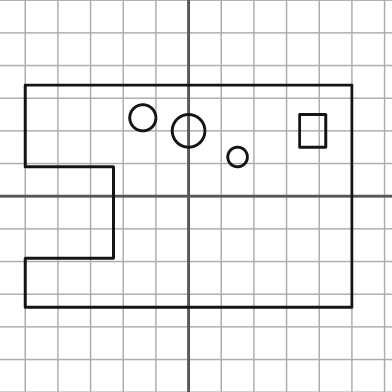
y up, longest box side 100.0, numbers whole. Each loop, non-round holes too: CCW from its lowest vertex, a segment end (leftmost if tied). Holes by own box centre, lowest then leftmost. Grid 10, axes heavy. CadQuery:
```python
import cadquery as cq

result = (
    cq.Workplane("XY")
    .moveTo(-50.0, -34.0)
    .lineTo(50.0, -34.0)
    .lineTo(50.0, 34.0)
    .lineTo(-50.0, 34.0)
    .lineTo(-50.0, 9.0)
    .lineTo(-23.0, 9.0)
    .lineTo(-23.0, -19.0)
    .lineTo(-50.0, -19.0)
    .close()
    .moveTo(15.0, 12.0)
    .circle(3.0)
    .moveTo(0.0, 20.0)
    .circle(5.0)
    .moveTo(34.0, 15.0)
    .lineTo(42.0, 15.0)
    .lineTo(42.0, 25.0)
    .lineTo(34.0, 25.0)
    .close()
    .moveTo(-14.0, 24.0)
    .circle(4.0)
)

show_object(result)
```